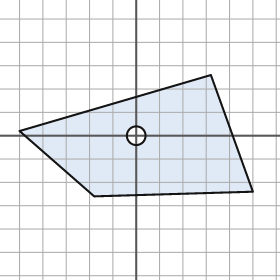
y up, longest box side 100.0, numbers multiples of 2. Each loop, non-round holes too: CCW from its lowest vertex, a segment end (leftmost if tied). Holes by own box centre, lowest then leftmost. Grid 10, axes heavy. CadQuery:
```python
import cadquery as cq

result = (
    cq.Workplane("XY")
    .moveTo(-18.0, -26.0)
    .lineTo(50.0, -24.0)
    .lineTo(32.0, 26.0)
    .lineTo(-50.0, 2.0)
    .close()
    .moveTo(0.0, 0.0)
    .circle(4.0)
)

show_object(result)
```